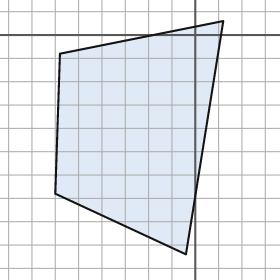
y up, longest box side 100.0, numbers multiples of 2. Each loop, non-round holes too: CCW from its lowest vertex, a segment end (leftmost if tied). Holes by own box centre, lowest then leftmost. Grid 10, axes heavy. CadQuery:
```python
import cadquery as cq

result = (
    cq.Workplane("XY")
    .moveTo(-4.0, -94.0)
    .lineTo(12.0, 6.0)
    .lineTo(-58.0, -8.0)
    .lineTo(-60.0, -68.0)
    .close()
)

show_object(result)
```